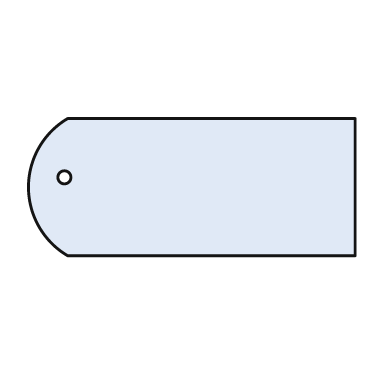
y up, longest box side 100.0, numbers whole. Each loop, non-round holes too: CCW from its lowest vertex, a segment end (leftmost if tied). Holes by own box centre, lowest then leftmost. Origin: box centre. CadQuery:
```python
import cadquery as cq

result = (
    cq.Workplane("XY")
    .moveTo(-38.0, -21.0)
    .lineTo(50.0, -21.0)
    .lineTo(50.0, 21.0)
    .lineTo(-38.0, 21.0)
    .threePointArc((-50.0, 0.0), (-38.0, -21.0))
    .close()
    .moveTo(-39.0, 3.0)
    .circle(2.0)
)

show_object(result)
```